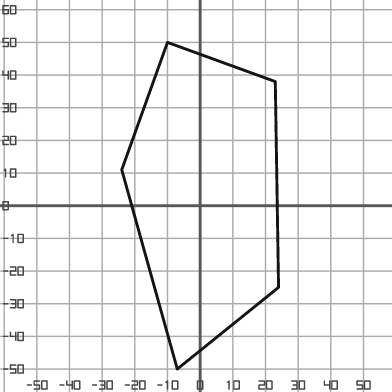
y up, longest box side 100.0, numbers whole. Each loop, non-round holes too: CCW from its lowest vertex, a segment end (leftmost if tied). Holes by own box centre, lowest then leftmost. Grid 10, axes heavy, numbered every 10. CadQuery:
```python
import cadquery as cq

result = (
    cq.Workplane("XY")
    .moveTo(-7.0, -50.0)
    .lineTo(24.0, -25.0)
    .lineTo(23.0, 38.0)
    .lineTo(-10.0, 50.0)
    .lineTo(-24.0, 11.0)
    .close()
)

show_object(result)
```